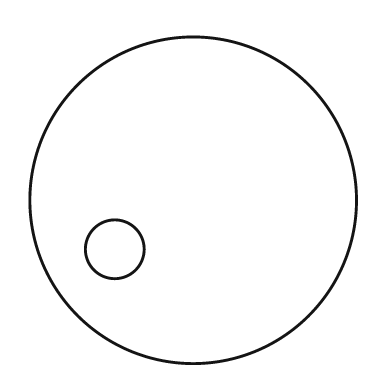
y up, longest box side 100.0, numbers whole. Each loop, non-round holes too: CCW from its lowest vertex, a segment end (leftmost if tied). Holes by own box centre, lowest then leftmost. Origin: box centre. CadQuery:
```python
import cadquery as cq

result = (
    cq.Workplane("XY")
    .moveTo(0.0, 0.0)
    .circle(50.0)
    .moveTo(-24.0, -15.0)
    .circle(9.0)
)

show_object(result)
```